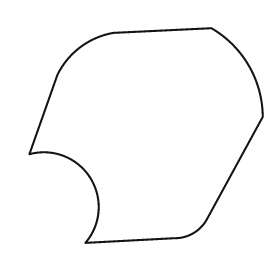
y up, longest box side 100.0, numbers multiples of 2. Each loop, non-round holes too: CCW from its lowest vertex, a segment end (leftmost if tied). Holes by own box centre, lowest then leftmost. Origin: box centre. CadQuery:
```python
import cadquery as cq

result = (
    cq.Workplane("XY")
    .moveTo(-26.0, -46.0)
    .lineTo(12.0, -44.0)
    .threePointArc((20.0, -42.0), (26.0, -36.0))
    .lineTo(50.0, 8.0)
    .threePointArc((44.0, 30.0), (28.0, 46.0))
    .lineTo(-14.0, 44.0)
    .threePointArc((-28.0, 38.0), (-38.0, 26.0))
    .lineTo(-50.0, -8.0)
    .threePointArc((-24.0, -18.0), (-26.0, -46.0))
    .close()
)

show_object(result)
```